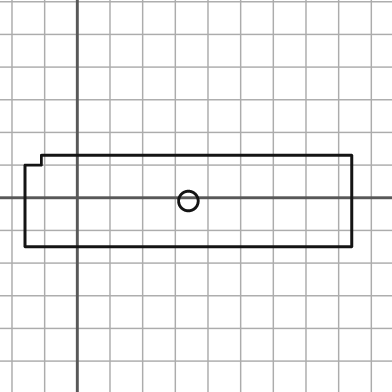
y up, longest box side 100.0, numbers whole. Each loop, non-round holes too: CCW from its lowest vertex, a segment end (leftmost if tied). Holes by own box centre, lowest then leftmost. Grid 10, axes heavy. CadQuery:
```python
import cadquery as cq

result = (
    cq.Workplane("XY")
    .moveTo(-16.0, -15.0)
    .lineTo(84.0, -15.0)
    .lineTo(84.0, 13.0)
    .lineTo(-11.0, 13.0)
    .lineTo(-11.0, 10.0)
    .lineTo(-16.0, 10.0)
    .close()
    .moveTo(34.0, -1.0)
    .circle(3.0)
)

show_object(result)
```